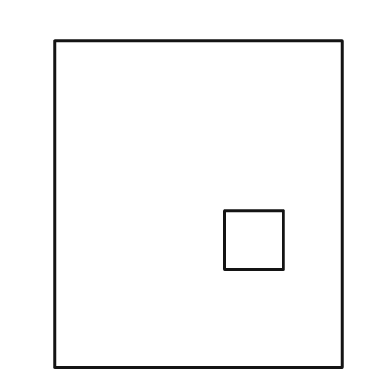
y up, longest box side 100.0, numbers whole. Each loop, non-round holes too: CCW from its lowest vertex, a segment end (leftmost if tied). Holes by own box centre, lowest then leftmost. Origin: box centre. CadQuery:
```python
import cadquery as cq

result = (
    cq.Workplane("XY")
    .moveTo(-44.0, -50.0)
    .lineTo(44.0, -50.0)
    .lineTo(44.0, 50.0)
    .lineTo(-44.0, 50.0)
    .close()
    .moveTo(8.0, -20.0)
    .lineTo(26.0, -20.0)
    .lineTo(26.0, -2.0)
    .lineTo(8.0, -2.0)
    .close()
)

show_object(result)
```